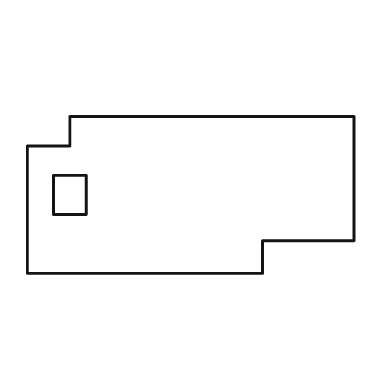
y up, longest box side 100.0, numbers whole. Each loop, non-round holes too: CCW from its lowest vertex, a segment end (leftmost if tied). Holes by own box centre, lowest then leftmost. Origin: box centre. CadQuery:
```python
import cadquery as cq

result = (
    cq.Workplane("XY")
    .moveTo(-50.0, -24.0)
    .lineTo(22.0, -24.0)
    .lineTo(22.0, -14.0)
    .lineTo(50.0, -14.0)
    .lineTo(50.0, 24.0)
    .lineTo(-37.0, 24.0)
    .lineTo(-37.0, 15.0)
    .lineTo(-50.0, 15.0)
    .close()
    .moveTo(-42.0, -6.0)
    .lineTo(-32.0, -6.0)
    .lineTo(-32.0, 6.0)
    .lineTo(-42.0, 6.0)
    .close()
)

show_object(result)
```